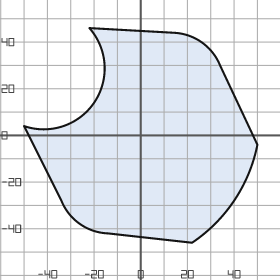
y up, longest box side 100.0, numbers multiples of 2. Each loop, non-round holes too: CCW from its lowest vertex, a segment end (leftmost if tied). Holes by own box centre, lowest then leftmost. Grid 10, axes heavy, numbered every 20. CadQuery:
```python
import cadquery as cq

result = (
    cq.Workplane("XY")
    .moveTo(22.0, -46.0)
    .threePointArc((40.0, -28.0), (50.0, -4.0))
    .lineTo(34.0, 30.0)
    .threePointArc((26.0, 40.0), (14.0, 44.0))
    .lineTo(-22.0, 46.0)
    .threePointArc((-20.0, 14.0), (-50.0, 4.0))
    .lineTo(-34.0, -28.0)
    .threePointArc((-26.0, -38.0), (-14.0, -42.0))
    .close()
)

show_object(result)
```